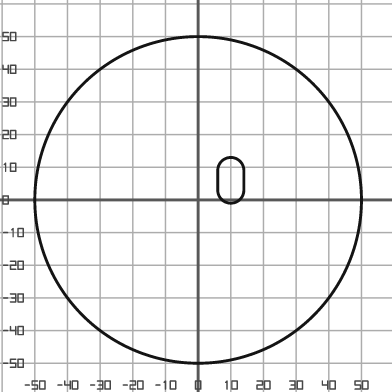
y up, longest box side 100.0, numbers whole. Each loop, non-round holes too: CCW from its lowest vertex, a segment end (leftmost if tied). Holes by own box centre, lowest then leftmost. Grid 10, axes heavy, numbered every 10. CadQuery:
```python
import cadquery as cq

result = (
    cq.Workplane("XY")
    .moveTo(0.0, 0.0)
    .circle(50.0)
    .moveTo(6.0, 3.0)
    .threePointArc((10.0, -1.0), (14.0, 3.0))
    .lineTo(14.0, 9.0)
    .threePointArc((10.0, 13.0), (6.0, 9.0))
    .close()
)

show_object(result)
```